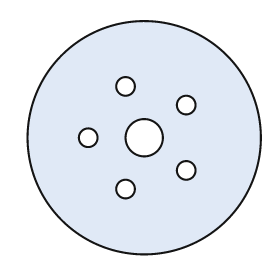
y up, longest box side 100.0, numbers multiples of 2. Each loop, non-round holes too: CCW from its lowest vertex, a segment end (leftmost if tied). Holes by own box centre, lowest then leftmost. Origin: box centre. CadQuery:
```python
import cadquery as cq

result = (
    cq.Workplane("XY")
    .moveTo(0.0, 0.0)
    .circle(50.0)
    .moveTo(-8.0, -22.0)
    .circle(4.0)
    .moveTo(18.0, -14.0)
    .circle(4.0)
    .moveTo(-24.0, 0.0)
    .circle(4.0)
    .moveTo(0.0, 0.0)
    .circle(8.0)
    .moveTo(18.0, 14.0)
    .circle(4.0)
    .moveTo(-8.0, 22.0)
    .circle(4.0)
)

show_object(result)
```